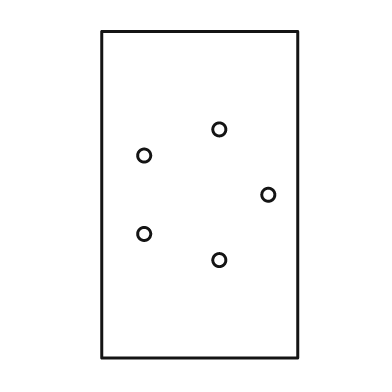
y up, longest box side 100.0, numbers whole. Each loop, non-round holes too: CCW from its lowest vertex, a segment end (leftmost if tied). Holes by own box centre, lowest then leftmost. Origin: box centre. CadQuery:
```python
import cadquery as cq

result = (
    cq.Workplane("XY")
    .moveTo(-30.0, -50.0)
    .lineTo(30.0, -50.0)
    .lineTo(30.0, 50.0)
    .lineTo(-30.0, 50.0)
    .close()
    .moveTo(6.0, -20.0)
    .circle(2.0)
    .moveTo(-17.0, -12.0)
    .circle(2.0)
    .moveTo(21.0, 0.0)
    .circle(2.0)
    .moveTo(-17.0, 12.0)
    .circle(2.0)
    .moveTo(6.0, 20.0)
    .circle(2.0)
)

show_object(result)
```